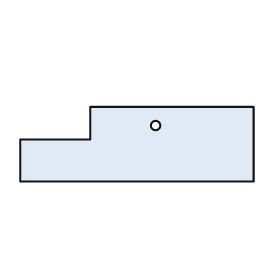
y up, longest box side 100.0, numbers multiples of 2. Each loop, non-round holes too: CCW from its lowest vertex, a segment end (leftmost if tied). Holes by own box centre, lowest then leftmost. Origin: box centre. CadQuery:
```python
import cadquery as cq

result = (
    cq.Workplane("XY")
    .moveTo(-50.0, -16.0)
    .lineTo(50.0, -16.0)
    .lineTo(50.0, 16.0)
    .lineTo(-20.0, 16.0)
    .lineTo(-20.0, 2.0)
    .lineTo(-50.0, 2.0)
    .close()
    .moveTo(8.0, 8.0)
    .circle(2.0)
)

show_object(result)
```